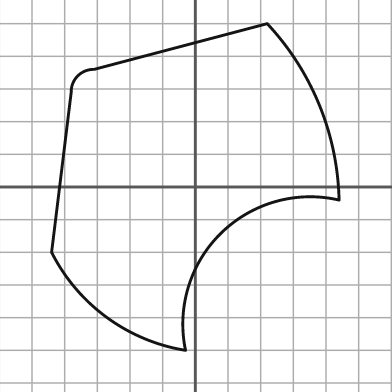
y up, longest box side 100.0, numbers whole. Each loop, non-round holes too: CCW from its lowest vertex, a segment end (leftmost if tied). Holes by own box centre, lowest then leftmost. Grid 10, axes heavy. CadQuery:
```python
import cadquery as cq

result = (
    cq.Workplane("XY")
    .moveTo(-3.0, -50.0)
    .threePointArc((8.0, -14.0), (44.0, -4.0))
    .threePointArc((38.0, 25.0), (22.0, 50.0))
    .lineTo(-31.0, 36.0)
    .threePointArc((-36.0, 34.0), (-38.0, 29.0))
    .lineTo(-44.0, -20.0)
    .threePointArc((-27.0, -40.0), (-3.0, -50.0))
    .close()
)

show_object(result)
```